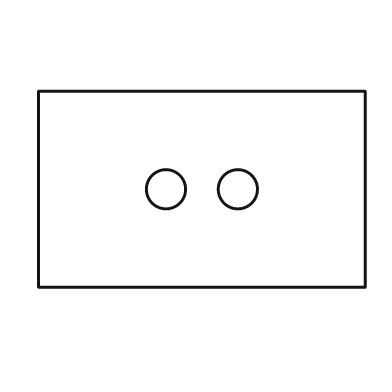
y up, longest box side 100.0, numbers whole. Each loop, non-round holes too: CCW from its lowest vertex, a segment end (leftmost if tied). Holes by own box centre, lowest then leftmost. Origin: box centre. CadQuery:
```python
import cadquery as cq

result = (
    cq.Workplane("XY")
    .moveTo(-50.0, -30.0)
    .lineTo(50.0, -30.0)
    .lineTo(50.0, 30.0)
    .lineTo(-50.0, 30.0)
    .close()
    .moveTo(-11.0, 0.0)
    .circle(6.0)
    .moveTo(11.0, 0.0)
    .circle(6.0)
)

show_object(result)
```